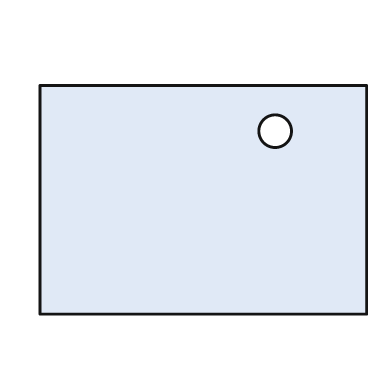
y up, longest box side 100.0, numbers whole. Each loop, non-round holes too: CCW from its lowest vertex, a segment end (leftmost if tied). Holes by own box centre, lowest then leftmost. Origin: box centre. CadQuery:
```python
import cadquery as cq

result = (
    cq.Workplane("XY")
    .moveTo(-50.0, -35.0)
    .lineTo(50.0, -35.0)
    .lineTo(50.0, 35.0)
    .lineTo(-50.0, 35.0)
    .close()
    .moveTo(22.0, 21.0)
    .circle(5.0)
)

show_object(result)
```